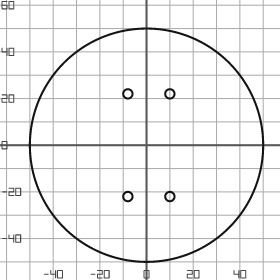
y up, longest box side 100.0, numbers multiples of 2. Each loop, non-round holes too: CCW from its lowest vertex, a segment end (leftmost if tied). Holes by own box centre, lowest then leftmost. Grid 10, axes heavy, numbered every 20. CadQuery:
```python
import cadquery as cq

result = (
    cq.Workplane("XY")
    .moveTo(0.0, 0.0)
    .circle(50.0)
    .moveTo(-8.0, -22.0)
    .circle(2.0)
    .moveTo(10.0, -22.0)
    .circle(2.0)
    .moveTo(-8.0, 22.0)
    .circle(2.0)
    .moveTo(10.0, 22.0)
    .circle(2.0)
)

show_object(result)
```